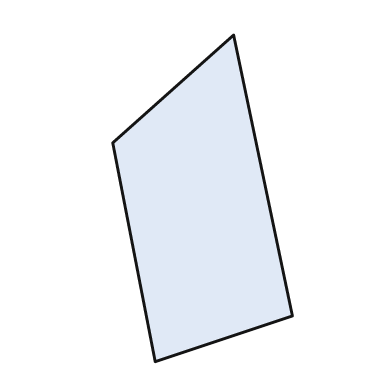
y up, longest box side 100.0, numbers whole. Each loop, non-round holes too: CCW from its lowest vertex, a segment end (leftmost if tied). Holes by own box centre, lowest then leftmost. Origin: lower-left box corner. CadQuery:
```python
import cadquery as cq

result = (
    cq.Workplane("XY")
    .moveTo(13.0, 0.0)
    .lineTo(55.0, 14.0)
    .lineTo(37.0, 100.0)
    .lineTo(0.0, 67.0)
    .close()
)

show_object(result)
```